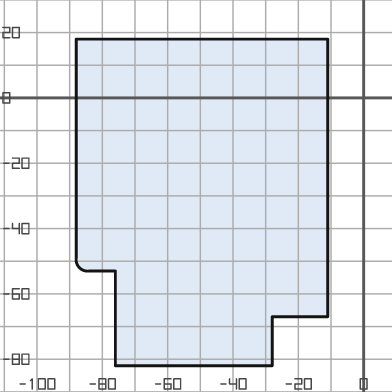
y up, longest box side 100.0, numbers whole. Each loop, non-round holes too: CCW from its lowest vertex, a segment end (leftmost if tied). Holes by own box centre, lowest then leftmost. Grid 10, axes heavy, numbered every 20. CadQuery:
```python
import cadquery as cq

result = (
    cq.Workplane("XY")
    .moveTo(-76.0, -82.0)
    .lineTo(-28.0, -82.0)
    .lineTo(-28.0, -67.0)
    .lineTo(-11.0, -67.0)
    .lineTo(-11.0, 18.0)
    .lineTo(-88.0, 18.0)
    .lineTo(-88.0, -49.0)
    .threePointArc((-87.0, -52.0), (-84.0, -53.0))
    .lineTo(-76.0, -53.0)
    .close()
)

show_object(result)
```